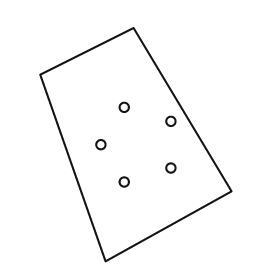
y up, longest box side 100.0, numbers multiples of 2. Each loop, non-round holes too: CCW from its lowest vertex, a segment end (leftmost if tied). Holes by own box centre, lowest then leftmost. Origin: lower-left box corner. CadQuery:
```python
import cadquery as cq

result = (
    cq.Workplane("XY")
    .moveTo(28.0, 0.0)
    .lineTo(82.0, 30.0)
    .lineTo(40.0, 100.0)
    .lineTo(0.0, 80.0)
    .close()
    .moveTo(36.0, 34.0)
    .circle(2.0)
    .moveTo(56.0, 40.0)
    .circle(2.0)
    .moveTo(26.0, 50.0)
    .circle(2.0)
    .moveTo(56.0, 60.0)
    .circle(2.0)
    .moveTo(36.0, 66.0)
    .circle(2.0)
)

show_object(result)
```